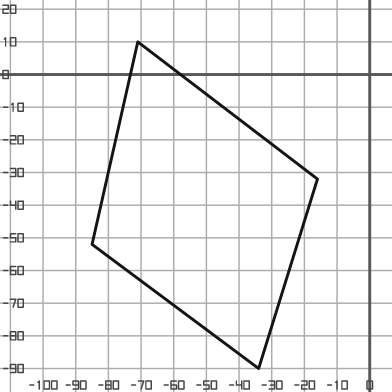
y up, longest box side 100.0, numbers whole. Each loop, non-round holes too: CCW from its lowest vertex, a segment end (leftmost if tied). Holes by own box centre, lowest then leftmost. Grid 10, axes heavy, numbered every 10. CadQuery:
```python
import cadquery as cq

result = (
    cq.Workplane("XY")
    .moveTo(-34.0, -90.0)
    .lineTo(-16.0, -32.0)
    .lineTo(-71.0, 10.0)
    .lineTo(-85.0, -52.0)
    .close()
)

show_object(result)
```